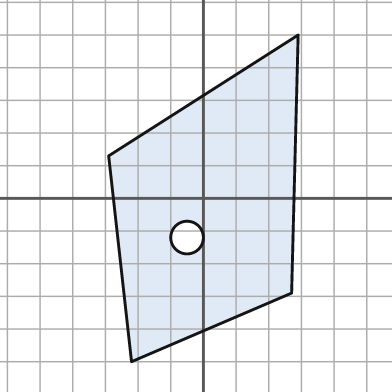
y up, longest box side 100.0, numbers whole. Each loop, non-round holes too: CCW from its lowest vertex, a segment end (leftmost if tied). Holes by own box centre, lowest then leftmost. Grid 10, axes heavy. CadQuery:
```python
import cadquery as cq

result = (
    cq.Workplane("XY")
    .moveTo(-22.0, -50.0)
    .lineTo(27.0, -29.0)
    .lineTo(29.0, 50.0)
    .lineTo(-29.0, 13.0)
    .close()
    .moveTo(-5.0, -12.0)
    .circle(5.0)
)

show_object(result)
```